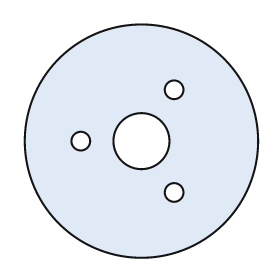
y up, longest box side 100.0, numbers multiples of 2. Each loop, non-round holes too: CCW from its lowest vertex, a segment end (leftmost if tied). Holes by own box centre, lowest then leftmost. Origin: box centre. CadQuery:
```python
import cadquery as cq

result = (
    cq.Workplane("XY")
    .moveTo(0.0, 0.0)
    .circle(50.0)
    .moveTo(14.0, -22.0)
    .circle(4.0)
    .moveTo(-26.0, 0.0)
    .circle(4.0)
    .moveTo(0.0, 0.0)
    .circle(12.0)
    .moveTo(14.0, 22.0)
    .circle(4.0)
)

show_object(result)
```